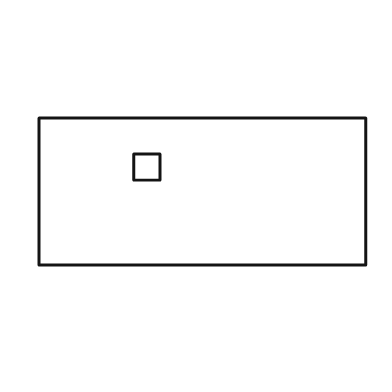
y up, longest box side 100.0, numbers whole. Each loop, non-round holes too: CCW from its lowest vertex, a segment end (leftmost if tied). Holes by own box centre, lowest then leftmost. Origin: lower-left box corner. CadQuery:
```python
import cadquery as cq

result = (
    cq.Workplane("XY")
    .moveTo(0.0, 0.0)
    .lineTo(100.0, 0.0)
    .lineTo(100.0, 45.0)
    .lineTo(0.0, 45.0)
    .close()
    .moveTo(29.0, 26.0)
    .lineTo(37.0, 26.0)
    .lineTo(37.0, 34.0)
    .lineTo(29.0, 34.0)
    .close()
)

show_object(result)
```